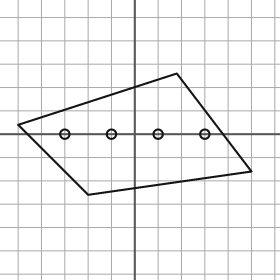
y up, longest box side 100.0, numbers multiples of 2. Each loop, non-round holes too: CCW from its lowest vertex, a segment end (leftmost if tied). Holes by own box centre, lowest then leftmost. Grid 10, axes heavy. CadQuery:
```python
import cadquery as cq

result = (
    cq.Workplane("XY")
    .moveTo(-20.0, -26.0)
    .lineTo(50.0, -16.0)
    .lineTo(18.0, 26.0)
    .lineTo(-50.0, 4.0)
    .close()
    .moveTo(-30.0, 0.0)
    .circle(2.0)
    .moveTo(-10.0, 0.0)
    .circle(2.0)
    .moveTo(10.0, 0.0)
    .circle(2.0)
    .moveTo(30.0, 0.0)
    .circle(2.0)
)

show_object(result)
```